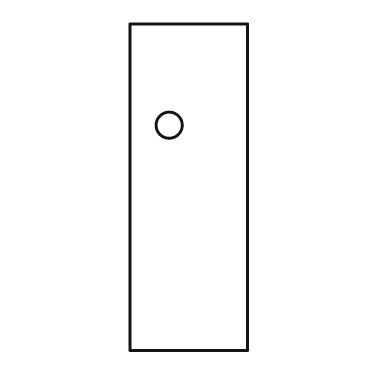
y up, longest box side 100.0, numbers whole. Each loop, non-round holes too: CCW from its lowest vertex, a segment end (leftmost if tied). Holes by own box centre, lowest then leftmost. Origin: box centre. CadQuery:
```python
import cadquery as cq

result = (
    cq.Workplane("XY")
    .moveTo(-18.0, -50.0)
    .lineTo(18.0, -50.0)
    .lineTo(18.0, 50.0)
    .lineTo(-18.0, 50.0)
    .close()
    .moveTo(-6.0, 19.0)
    .circle(4.0)
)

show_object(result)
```